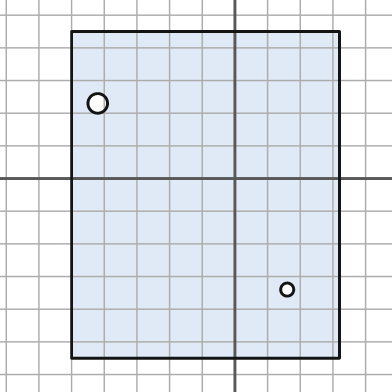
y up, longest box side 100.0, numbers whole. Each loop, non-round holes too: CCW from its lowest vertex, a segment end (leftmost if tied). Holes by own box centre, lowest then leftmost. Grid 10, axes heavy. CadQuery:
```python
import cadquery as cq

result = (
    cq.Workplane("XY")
    .moveTo(-50.0, -55.0)
    .lineTo(32.0, -55.0)
    .lineTo(32.0, 45.0)
    .lineTo(-50.0, 45.0)
    .close()
    .moveTo(16.0, -34.0)
    .circle(2.0)
    .moveTo(-42.0, 23.0)
    .circle(3.0)
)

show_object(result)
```